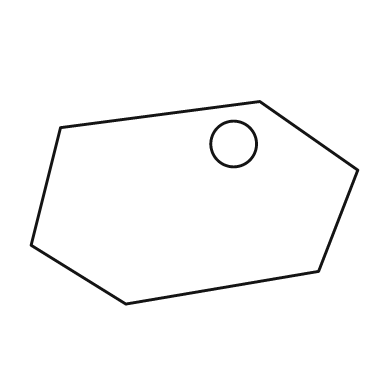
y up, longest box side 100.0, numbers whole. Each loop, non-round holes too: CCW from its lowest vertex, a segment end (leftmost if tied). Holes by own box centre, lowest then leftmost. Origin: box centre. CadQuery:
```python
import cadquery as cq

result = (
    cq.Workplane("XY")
    .moveTo(-21.0, -31.0)
    .lineTo(38.0, -21.0)
    .lineTo(50.0, 10.0)
    .lineTo(20.0, 31.0)
    .lineTo(-41.0, 23.0)
    .lineTo(-50.0, -13.0)
    .close()
    .moveTo(12.0, 18.0)
    .circle(7.0)
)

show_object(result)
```